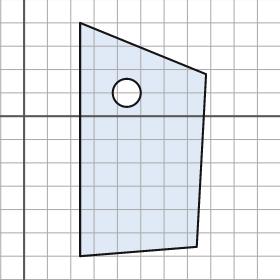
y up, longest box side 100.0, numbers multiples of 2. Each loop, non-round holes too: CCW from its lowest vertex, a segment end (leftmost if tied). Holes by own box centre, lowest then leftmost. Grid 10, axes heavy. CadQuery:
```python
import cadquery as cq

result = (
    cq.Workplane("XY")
    .moveTo(24.0, -60.0)
    .lineTo(74.0, -56.0)
    .lineTo(78.0, 18.0)
    .lineTo(24.0, 40.0)
    .close()
    .moveTo(44.0, 10.0)
    .circle(6.0)
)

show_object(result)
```